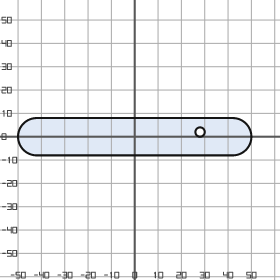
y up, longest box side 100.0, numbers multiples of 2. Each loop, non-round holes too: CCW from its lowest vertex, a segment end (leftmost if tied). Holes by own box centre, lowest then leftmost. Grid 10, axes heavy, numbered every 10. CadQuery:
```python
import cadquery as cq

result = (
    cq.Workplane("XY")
    .moveTo(-42.0, -8.0)
    .lineTo(42.0, -8.0)
    .threePointArc((50.0, 0.0), (42.0, 8.0))
    .lineTo(-42.0, 8.0)
    .threePointArc((-50.0, 0.0), (-42.0, -8.0))
    .close()
    .moveTo(28.0, 2.0)
    .circle(2.0)
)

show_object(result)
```